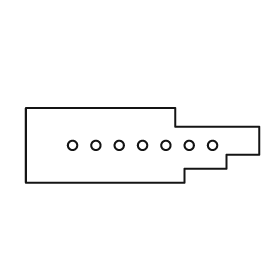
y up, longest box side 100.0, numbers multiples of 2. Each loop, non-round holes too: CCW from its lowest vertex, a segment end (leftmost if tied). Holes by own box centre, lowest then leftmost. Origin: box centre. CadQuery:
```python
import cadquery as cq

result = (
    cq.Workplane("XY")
    .moveTo(-50.0, -16.0)
    .lineTo(18.0, -16.0)
    .lineTo(18.0, -10.0)
    .lineTo(36.0, -10.0)
    .lineTo(36.0, -4.0)
    .lineTo(50.0, -4.0)
    .lineTo(50.0, 8.0)
    .lineTo(14.0, 8.0)
    .lineTo(14.0, 16.0)
    .lineTo(-50.0, 16.0)
    .close()
    .moveTo(-30.0, 0.0)
    .circle(2.0)
    .moveTo(-20.0, 0.0)
    .circle(2.0)
    .moveTo(-10.0, 0.0)
    .circle(2.0)
    .moveTo(0.0, 0.0)
    .circle(2.0)
    .moveTo(10.0, 0.0)
    .circle(2.0)
    .moveTo(20.0, 0.0)
    .circle(2.0)
    .moveTo(30.0, 0.0)
    .circle(2.0)
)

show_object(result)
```